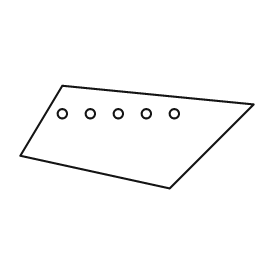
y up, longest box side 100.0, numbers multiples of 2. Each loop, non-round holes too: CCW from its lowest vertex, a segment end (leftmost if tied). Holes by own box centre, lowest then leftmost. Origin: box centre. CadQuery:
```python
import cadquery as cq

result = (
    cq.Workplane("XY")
    .moveTo(14.0, -22.0)
    .lineTo(50.0, 14.0)
    .lineTo(-32.0, 22.0)
    .lineTo(-50.0, -8.0)
    .close()
    .moveTo(-32.0, 10.0)
    .circle(2.0)
    .moveTo(-20.0, 10.0)
    .circle(2.0)
    .moveTo(-8.0, 10.0)
    .circle(2.0)
    .moveTo(4.0, 10.0)
    .circle(2.0)
    .moveTo(16.0, 10.0)
    .circle(2.0)
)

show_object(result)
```